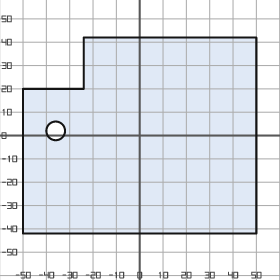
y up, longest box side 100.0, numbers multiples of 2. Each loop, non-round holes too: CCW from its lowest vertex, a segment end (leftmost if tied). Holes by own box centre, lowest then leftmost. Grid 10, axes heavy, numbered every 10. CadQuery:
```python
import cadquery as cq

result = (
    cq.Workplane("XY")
    .moveTo(-50.0, -42.0)
    .lineTo(50.0, -42.0)
    .lineTo(50.0, 42.0)
    .lineTo(-24.0, 42.0)
    .lineTo(-24.0, 20.0)
    .lineTo(-50.0, 20.0)
    .close()
    .moveTo(-36.0, 2.0)
    .circle(4.0)
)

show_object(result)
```